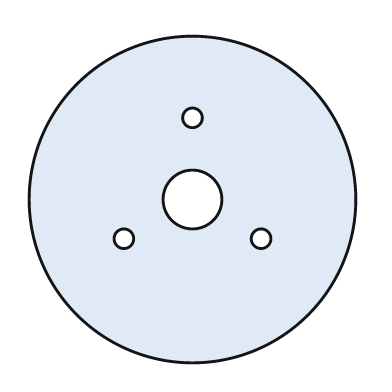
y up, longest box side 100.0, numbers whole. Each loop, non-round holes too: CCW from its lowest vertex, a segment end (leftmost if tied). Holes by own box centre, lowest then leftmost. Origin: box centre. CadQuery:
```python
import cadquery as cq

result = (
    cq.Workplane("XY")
    .moveTo(0.0, 0.0)
    .circle(50.0)
    .moveTo(-21.0, -12.0)
    .circle(3.0)
    .moveTo(21.0, -12.0)
    .circle(3.0)
    .moveTo(0.0, 0.0)
    .circle(9.0)
    .moveTo(0.0, 25.0)
    .circle(3.0)
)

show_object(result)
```